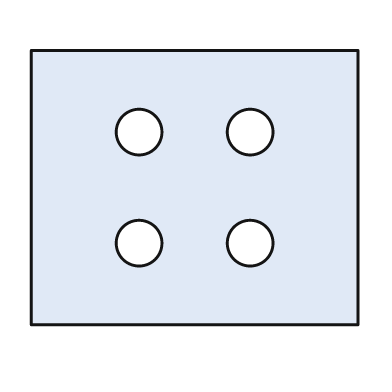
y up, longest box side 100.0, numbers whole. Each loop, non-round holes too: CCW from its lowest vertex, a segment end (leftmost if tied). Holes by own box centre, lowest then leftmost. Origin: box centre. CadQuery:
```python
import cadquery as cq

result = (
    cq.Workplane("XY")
    .moveTo(-50.0, -42.0)
    .lineTo(50.0, -42.0)
    .lineTo(50.0, 42.0)
    .lineTo(-50.0, 42.0)
    .close()
    .moveTo(-17.0, -17.0)
    .circle(7.0)
    .moveTo(17.0, -17.0)
    .circle(7.0)
    .moveTo(-17.0, 17.0)
    .circle(7.0)
    .moveTo(17.0, 17.0)
    .circle(7.0)
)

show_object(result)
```